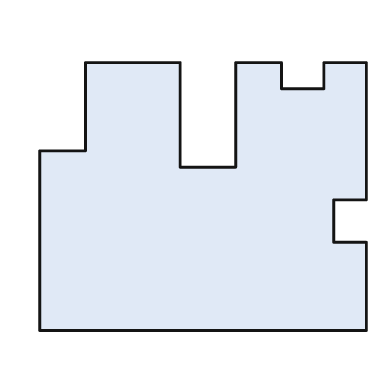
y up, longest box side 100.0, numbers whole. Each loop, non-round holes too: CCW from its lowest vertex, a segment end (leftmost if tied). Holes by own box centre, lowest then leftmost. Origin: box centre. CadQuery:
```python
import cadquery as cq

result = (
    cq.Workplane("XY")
    .moveTo(-50.0, -41.0)
    .lineTo(50.0, -41.0)
    .lineTo(50.0, -14.0)
    .lineTo(40.0, -14.0)
    .lineTo(40.0, -1.0)
    .lineTo(50.0, -1.0)
    .lineTo(50.0, 41.0)
    .lineTo(37.0, 41.0)
    .lineTo(37.0, 33.0)
    .lineTo(24.0, 33.0)
    .lineTo(24.0, 41.0)
    .lineTo(10.0, 41.0)
    .lineTo(10.0, 9.0)
    .lineTo(-7.0, 9.0)
    .lineTo(-7.0, 41.0)
    .lineTo(-36.0, 41.0)
    .lineTo(-36.0, 14.0)
    .lineTo(-50.0, 14.0)
    .close()
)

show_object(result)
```